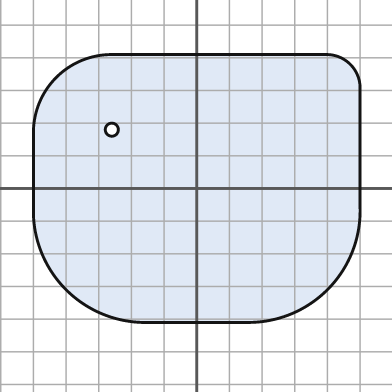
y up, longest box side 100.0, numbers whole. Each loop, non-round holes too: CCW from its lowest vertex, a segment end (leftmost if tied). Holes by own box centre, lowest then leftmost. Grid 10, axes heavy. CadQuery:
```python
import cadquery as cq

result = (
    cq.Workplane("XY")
    .moveTo(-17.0, -41.0)
    .lineTo(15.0, -41.0)
    .threePointArc((40.0, -31.0), (50.0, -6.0))
    .lineTo(50.0, 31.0)
    .threePointArc((47.0, 38.0), (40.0, 41.0))
    .lineTo(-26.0, 41.0)
    .threePointArc((-43.0, 34.0), (-50.0, 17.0))
    .lineTo(-50.0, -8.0)
    .threePointArc((-40.0, -31.0), (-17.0, -41.0))
    .close()
    .moveTo(-26.0, 18.0)
    .circle(2.0)
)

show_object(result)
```